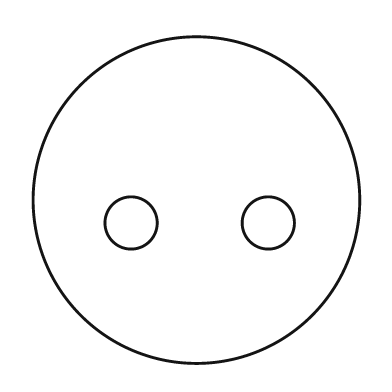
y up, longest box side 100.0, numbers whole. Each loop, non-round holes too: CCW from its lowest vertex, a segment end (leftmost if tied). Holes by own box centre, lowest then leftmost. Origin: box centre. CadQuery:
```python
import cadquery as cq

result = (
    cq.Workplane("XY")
    .moveTo(0.0, 0.0)
    .circle(50.0)
    .moveTo(-20.0, -7.0)
    .circle(8.0)
    .moveTo(22.0, -7.0)
    .circle(8.0)
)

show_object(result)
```